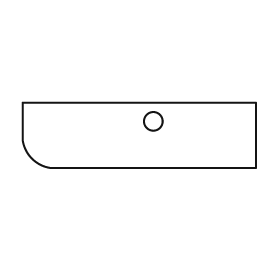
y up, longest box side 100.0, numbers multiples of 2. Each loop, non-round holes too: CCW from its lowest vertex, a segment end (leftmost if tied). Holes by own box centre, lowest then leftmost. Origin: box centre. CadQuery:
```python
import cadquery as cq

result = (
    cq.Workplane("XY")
    .moveTo(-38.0, -14.0)
    .lineTo(50.0, -14.0)
    .lineTo(50.0, 14.0)
    .lineTo(-50.0, 14.0)
    .lineTo(-50.0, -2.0)
    .threePointArc((-46.0, -10.0), (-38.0, -14.0))
    .close()
    .moveTo(6.0, 6.0)
    .circle(4.0)
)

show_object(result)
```